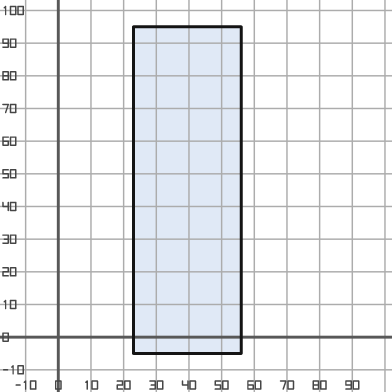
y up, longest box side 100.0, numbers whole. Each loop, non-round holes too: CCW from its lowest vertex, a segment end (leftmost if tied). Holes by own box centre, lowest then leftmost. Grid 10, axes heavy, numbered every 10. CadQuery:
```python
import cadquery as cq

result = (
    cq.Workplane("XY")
    .moveTo(23.0, -5.0)
    .lineTo(56.0, -5.0)
    .lineTo(56.0, 95.0)
    .lineTo(23.0, 95.0)
    .close()
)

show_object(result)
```